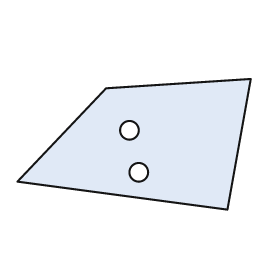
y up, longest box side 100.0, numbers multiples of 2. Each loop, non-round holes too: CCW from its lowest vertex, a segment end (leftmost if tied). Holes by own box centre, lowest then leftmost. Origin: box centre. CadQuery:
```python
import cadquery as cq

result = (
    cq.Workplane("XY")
    .moveTo(40.0, -28.0)
    .lineTo(50.0, 28.0)
    .lineTo(-12.0, 24.0)
    .lineTo(-50.0, -16.0)
    .close()
    .moveTo(2.0, -12.0)
    .circle(4.0)
    .moveTo(-2.0, 6.0)
    .circle(4.0)
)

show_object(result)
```